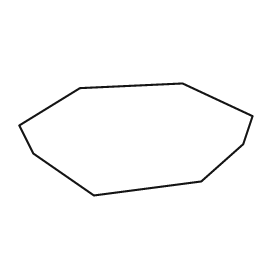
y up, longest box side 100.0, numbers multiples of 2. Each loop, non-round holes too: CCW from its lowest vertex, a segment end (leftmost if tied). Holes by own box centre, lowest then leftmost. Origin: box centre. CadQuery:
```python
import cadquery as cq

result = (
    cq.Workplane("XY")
    .moveTo(-18.0, -24.0)
    .lineTo(28.0, -18.0)
    .lineTo(46.0, -2.0)
    .lineTo(50.0, 10.0)
    .lineTo(20.0, 24.0)
    .lineTo(-24.0, 22.0)
    .lineTo(-50.0, 6.0)
    .lineTo(-44.0, -6.0)
    .close()
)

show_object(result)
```